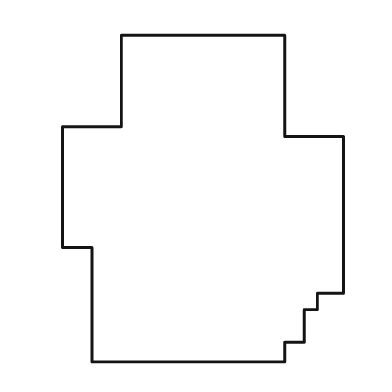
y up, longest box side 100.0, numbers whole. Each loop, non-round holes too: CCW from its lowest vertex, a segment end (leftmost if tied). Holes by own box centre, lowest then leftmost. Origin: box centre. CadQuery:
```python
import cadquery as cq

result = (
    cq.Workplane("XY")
    .moveTo(-34.0, -50.0)
    .lineTo(25.0, -50.0)
    .lineTo(25.0, -44.0)
    .lineTo(31.0, -44.0)
    .lineTo(31.0, -34.0)
    .lineTo(35.0, -34.0)
    .lineTo(35.0, -29.0)
    .lineTo(43.0, -29.0)
    .lineTo(43.0, 19.0)
    .lineTo(25.0, 19.0)
    .lineTo(25.0, 50.0)
    .lineTo(-25.0, 50.0)
    .lineTo(-25.0, 22.0)
    .lineTo(-43.0, 22.0)
    .lineTo(-43.0, -15.0)
    .lineTo(-34.0, -15.0)
    .close()
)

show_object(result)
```